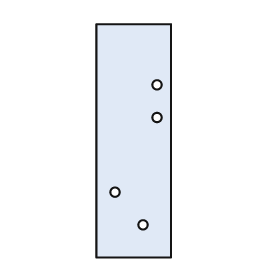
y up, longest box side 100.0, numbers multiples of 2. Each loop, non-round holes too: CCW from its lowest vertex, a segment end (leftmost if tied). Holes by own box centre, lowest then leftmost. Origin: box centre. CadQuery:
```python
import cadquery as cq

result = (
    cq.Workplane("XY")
    .moveTo(-16.0, -50.0)
    .lineTo(16.0, -50.0)
    .lineTo(16.0, 50.0)
    .lineTo(-16.0, 50.0)
    .close()
    .moveTo(4.0, -36.0)
    .circle(2.0)
    .moveTo(-8.0, -22.0)
    .circle(2.0)
    .moveTo(10.0, 10.0)
    .circle(2.0)
    .moveTo(10.0, 24.0)
    .circle(2.0)
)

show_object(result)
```